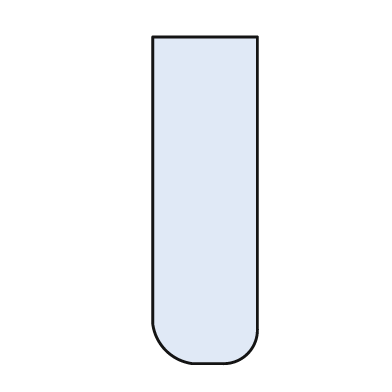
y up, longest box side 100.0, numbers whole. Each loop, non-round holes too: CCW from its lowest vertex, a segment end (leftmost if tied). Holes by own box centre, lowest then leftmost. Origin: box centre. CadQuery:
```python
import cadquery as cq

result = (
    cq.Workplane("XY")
    .moveTo(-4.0, -50.0)
    .lineTo(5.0, -50.0)
    .threePointArc((13.0, -47.0), (16.0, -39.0))
    .lineTo(16.0, 50.0)
    .lineTo(-16.0, 50.0)
    .lineTo(-16.0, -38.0)
    .threePointArc((-12.0, -46.0), (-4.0, -50.0))
    .close()
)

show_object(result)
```